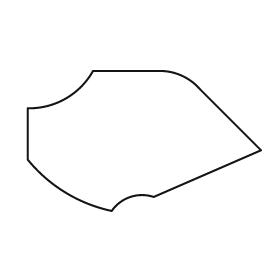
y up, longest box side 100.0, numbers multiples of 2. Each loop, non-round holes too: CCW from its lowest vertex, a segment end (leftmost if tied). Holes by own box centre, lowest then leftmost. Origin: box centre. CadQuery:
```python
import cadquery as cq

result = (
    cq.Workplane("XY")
    .moveTo(-14.0, -30.0)
    .threePointArc((-6.0, -24.0), (4.0, -24.0))
    .lineTo(50.0, -4.0)
    .lineTo(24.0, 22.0)
    .threePointArc((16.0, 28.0), (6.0, 30.0))
    .lineTo(-22.0, 30.0)
    .threePointArc((-34.0, 18.0), (-50.0, 14.0))
    .lineTo(-50.0, -8.0)
    .threePointArc((-34.0, -22.0), (-14.0, -30.0))
    .close()
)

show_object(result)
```